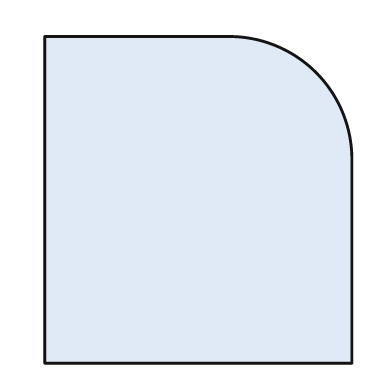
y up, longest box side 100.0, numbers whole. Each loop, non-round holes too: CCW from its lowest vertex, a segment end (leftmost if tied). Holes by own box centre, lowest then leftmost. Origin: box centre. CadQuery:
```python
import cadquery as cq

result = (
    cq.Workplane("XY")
    .moveTo(-47.0, -50.0)
    .lineTo(47.0, -50.0)
    .lineTo(47.0, 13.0)
    .threePointArc((36.0, 39.0), (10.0, 50.0))
    .lineTo(-47.0, 50.0)
    .close()
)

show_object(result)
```